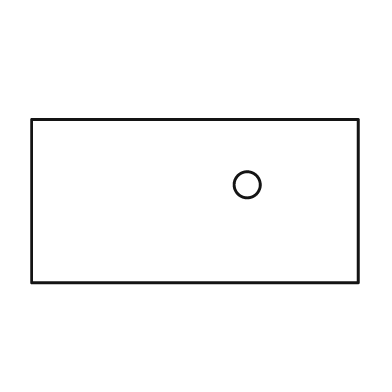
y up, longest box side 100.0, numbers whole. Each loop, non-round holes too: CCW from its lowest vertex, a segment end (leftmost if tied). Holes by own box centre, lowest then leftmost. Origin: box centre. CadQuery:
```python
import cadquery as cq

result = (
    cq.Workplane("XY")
    .moveTo(-50.0, -25.0)
    .lineTo(50.0, -25.0)
    .lineTo(50.0, 25.0)
    .lineTo(-50.0, 25.0)
    .close()
    .moveTo(16.0, 5.0)
    .circle(4.0)
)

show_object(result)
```